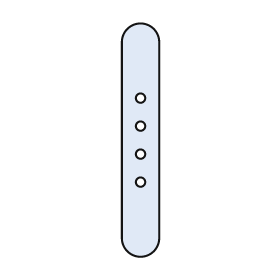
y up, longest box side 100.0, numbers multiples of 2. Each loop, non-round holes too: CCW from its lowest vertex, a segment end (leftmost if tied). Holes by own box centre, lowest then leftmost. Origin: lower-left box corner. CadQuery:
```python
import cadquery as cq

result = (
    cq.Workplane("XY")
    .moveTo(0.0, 8.0)
    .threePointArc((8.0, 0.0), (16.0, 8.0))
    .lineTo(16.0, 92.0)
    .threePointArc((8.0, 100.0), (0.0, 92.0))
    .close()
    .moveTo(8.0, 32.0)
    .circle(2.0)
    .moveTo(8.0, 44.0)
    .circle(2.0)
    .moveTo(8.0, 56.0)
    .circle(2.0)
    .moveTo(8.0, 68.0)
    .circle(2.0)
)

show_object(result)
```